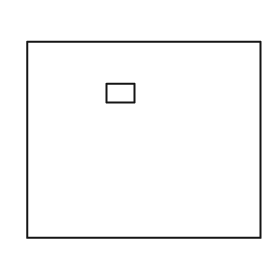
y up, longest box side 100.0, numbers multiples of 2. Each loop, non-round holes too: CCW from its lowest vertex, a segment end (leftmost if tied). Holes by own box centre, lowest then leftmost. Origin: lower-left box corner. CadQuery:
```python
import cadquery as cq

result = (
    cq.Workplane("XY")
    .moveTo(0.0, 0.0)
    .lineTo(100.0, 0.0)
    .lineTo(100.0, 84.0)
    .lineTo(0.0, 84.0)
    .close()
    .moveTo(34.0, 58.0)
    .lineTo(46.0, 58.0)
    .lineTo(46.0, 66.0)
    .lineTo(34.0, 66.0)
    .close()
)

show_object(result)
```